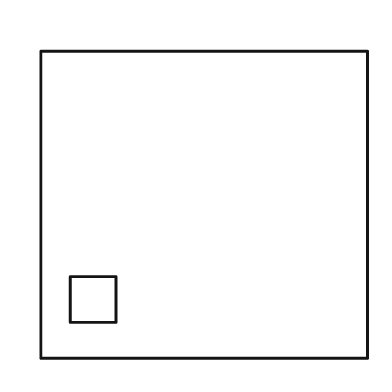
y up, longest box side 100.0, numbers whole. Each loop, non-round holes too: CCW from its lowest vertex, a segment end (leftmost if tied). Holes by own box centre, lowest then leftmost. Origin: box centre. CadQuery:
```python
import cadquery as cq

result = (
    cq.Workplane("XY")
    .moveTo(-50.0, -47.0)
    .lineTo(50.0, -47.0)
    .lineTo(50.0, 47.0)
    .lineTo(-50.0, 47.0)
    .close()
    .moveTo(-41.0, -36.0)
    .lineTo(-27.0, -36.0)
    .lineTo(-27.0, -22.0)
    .lineTo(-41.0, -22.0)
    .close()
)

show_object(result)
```